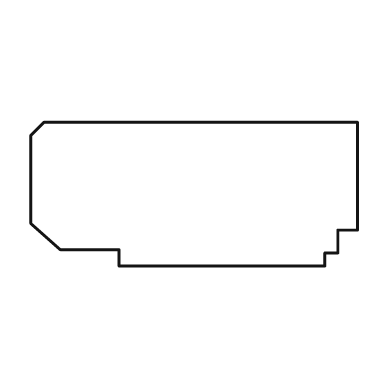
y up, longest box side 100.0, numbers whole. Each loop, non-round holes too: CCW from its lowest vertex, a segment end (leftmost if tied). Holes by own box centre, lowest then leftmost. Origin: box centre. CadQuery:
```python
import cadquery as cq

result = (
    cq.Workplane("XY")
    .moveTo(-23.0, -22.0)
    .lineTo(40.0, -22.0)
    .lineTo(40.0, -18.0)
    .lineTo(44.0, -18.0)
    .lineTo(44.0, -11.0)
    .lineTo(50.0, -11.0)
    .lineTo(50.0, 22.0)
    .lineTo(-46.0, 22.0)
    .lineTo(-50.0, 18.0)
    .lineTo(-50.0, -9.0)
    .lineTo(-41.0, -17.0)
    .lineTo(-23.0, -17.0)
    .close()
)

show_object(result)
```